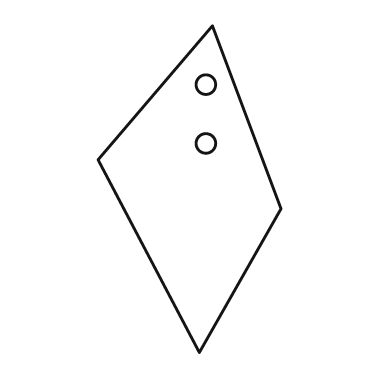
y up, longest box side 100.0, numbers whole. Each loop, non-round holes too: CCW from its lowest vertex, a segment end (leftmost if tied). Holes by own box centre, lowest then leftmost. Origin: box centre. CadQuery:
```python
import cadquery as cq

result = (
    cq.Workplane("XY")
    .moveTo(3.0, -50.0)
    .lineTo(28.0, -6.0)
    .lineTo(7.0, 50.0)
    .lineTo(-28.0, 9.0)
    .close()
    .moveTo(5.0, 14.0)
    .circle(3.0)
    .moveTo(5.0, 32.0)
    .circle(3.0)
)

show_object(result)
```